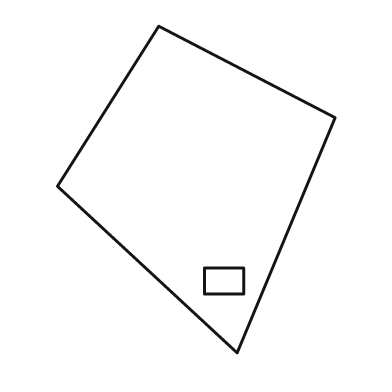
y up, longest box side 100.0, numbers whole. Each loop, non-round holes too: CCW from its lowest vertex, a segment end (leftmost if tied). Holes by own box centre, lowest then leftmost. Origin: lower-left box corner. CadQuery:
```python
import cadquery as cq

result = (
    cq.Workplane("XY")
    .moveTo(55.0, 0.0)
    .lineTo(85.0, 72.0)
    .lineTo(31.0, 100.0)
    .lineTo(0.0, 51.0)
    .close()
    .moveTo(45.0, 18.0)
    .lineTo(57.0, 18.0)
    .lineTo(57.0, 26.0)
    .lineTo(45.0, 26.0)
    .close()
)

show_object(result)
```